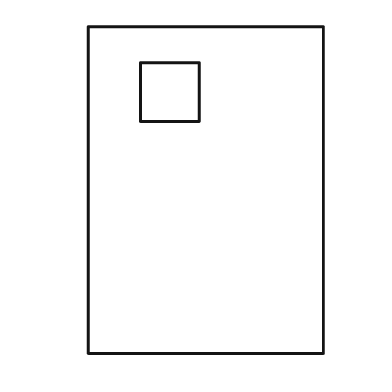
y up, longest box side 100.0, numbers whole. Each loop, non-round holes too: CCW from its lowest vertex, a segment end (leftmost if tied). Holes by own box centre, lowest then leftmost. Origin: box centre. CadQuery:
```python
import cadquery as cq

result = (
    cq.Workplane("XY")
    .moveTo(-36.0, -50.0)
    .lineTo(36.0, -50.0)
    .lineTo(36.0, 50.0)
    .lineTo(-36.0, 50.0)
    .close()
    .moveTo(-20.0, 21.0)
    .lineTo(-2.0, 21.0)
    .lineTo(-2.0, 39.0)
    .lineTo(-20.0, 39.0)
    .close()
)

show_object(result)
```